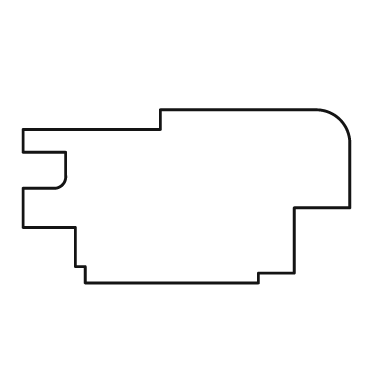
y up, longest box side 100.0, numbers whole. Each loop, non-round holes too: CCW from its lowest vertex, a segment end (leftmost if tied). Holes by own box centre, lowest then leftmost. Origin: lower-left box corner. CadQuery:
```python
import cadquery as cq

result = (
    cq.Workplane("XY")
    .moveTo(19.0, 0.0)
    .lineTo(72.0, 0.0)
    .lineTo(72.0, 3.0)
    .lineTo(83.0, 3.0)
    .lineTo(83.0, 23.0)
    .lineTo(100.0, 23.0)
    .lineTo(100.0, 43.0)
    .threePointArc((97.0, 50.0), (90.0, 53.0))
    .lineTo(42.0, 53.0)
    .lineTo(42.0, 47.0)
    .lineTo(0.0, 47.0)
    .lineTo(0.0, 40.0)
    .lineTo(13.0, 40.0)
    .lineTo(13.0, 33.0)
    .threePointArc((12.0, 30.0), (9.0, 29.0))
    .lineTo(0.0, 29.0)
    .lineTo(0.0, 17.0)
    .lineTo(16.0, 17.0)
    .lineTo(16.0, 5.0)
    .lineTo(19.0, 5.0)
    .close()
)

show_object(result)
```